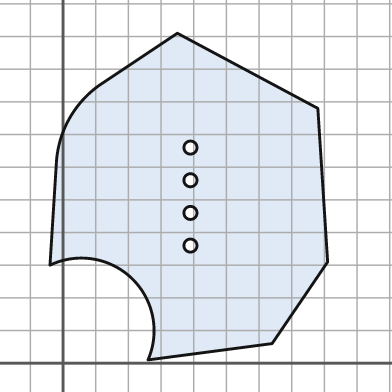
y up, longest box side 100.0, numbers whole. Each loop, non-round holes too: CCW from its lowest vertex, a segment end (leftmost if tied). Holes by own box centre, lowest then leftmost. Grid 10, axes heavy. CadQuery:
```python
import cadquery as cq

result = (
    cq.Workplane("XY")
    .moveTo(26.0, 1.0)
    .lineTo(64.0, 6.0)
    .lineTo(81.0, 31.0)
    .lineTo(78.0, 78.0)
    .lineTo(35.0, 101.0)
    .lineTo(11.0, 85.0)
    .threePointArc((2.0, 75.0), (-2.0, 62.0))
    .lineTo(-4.0, 30.0)
    .threePointArc((21.0, 26.0), (26.0, 1.0))
    .close()
    .moveTo(39.0, 36.0)
    .circle(2.0)
    .moveTo(39.0, 46.0)
    .circle(2.0)
    .moveTo(39.0, 56.0)
    .circle(2.0)
    .moveTo(39.0, 66.0)
    .circle(2.0)
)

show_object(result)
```